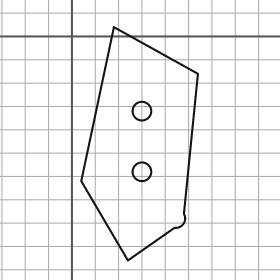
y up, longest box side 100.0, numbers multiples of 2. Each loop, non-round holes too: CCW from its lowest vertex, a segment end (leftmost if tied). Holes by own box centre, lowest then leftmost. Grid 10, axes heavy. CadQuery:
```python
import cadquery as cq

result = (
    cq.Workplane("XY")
    .moveTo(24.0, -96.0)
    .lineTo(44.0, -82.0)
    .threePointArc((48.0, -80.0), (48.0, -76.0))
    .lineTo(54.0, -16.0)
    .lineTo(18.0, 4.0)
    .lineTo(4.0, -62.0)
    .close()
    .moveTo(30.0, -58.0)
    .circle(4.0)
    .moveTo(30.0, -32.0)
    .circle(4.0)
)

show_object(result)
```